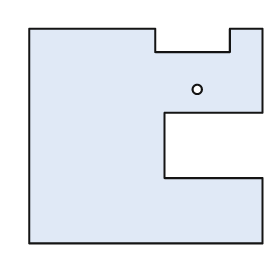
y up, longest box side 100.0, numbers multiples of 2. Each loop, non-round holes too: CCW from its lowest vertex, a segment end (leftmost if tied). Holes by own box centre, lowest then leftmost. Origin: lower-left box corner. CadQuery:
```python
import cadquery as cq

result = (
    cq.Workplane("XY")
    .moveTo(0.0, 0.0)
    .lineTo(100.0, 0.0)
    .lineTo(100.0, 28.0)
    .lineTo(58.0, 28.0)
    .lineTo(58.0, 56.0)
    .lineTo(100.0, 56.0)
    .lineTo(100.0, 92.0)
    .lineTo(86.0, 92.0)
    .lineTo(86.0, 82.0)
    .lineTo(54.0, 82.0)
    .lineTo(54.0, 92.0)
    .lineTo(0.0, 92.0)
    .close()
    .moveTo(72.0, 66.0)
    .circle(2.0)
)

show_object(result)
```